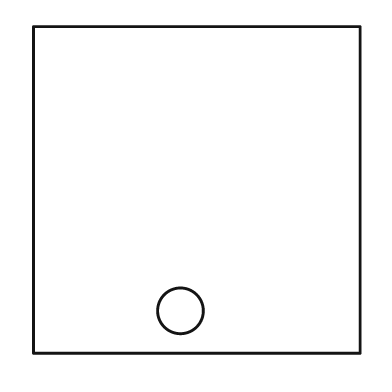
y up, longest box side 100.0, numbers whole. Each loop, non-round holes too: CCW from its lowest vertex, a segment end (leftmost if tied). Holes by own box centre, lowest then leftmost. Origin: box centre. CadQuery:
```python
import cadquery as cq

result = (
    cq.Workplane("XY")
    .moveTo(-50.0, -50.0)
    .lineTo(50.0, -50.0)
    .lineTo(50.0, 50.0)
    .lineTo(-50.0, 50.0)
    .close()
    .moveTo(-5.0, -37.0)
    .circle(7.0)
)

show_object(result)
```